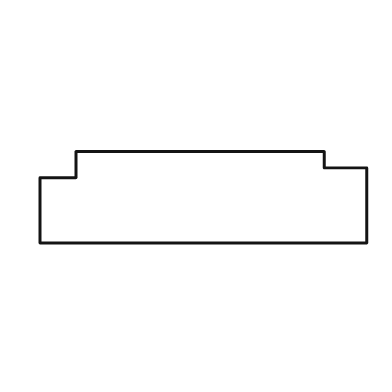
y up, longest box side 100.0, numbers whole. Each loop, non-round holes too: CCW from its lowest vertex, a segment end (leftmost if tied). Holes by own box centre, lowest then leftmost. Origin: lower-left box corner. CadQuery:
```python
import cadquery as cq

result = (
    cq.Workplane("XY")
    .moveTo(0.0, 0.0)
    .lineTo(100.0, 0.0)
    .lineTo(100.0, 23.0)
    .lineTo(87.0, 23.0)
    .lineTo(87.0, 28.0)
    .lineTo(11.0, 28.0)
    .lineTo(11.0, 20.0)
    .lineTo(0.0, 20.0)
    .close()
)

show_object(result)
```